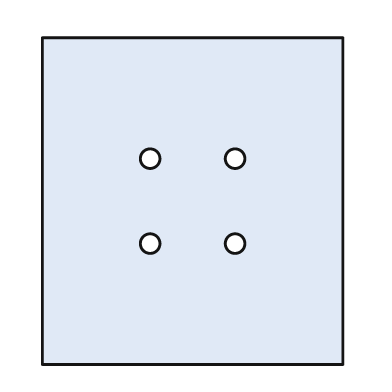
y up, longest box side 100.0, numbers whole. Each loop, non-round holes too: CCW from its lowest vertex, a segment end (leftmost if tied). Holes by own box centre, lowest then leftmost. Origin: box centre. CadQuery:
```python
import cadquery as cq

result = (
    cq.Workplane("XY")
    .moveTo(-46.0, -50.0)
    .lineTo(46.0, -50.0)
    .lineTo(46.0, 50.0)
    .lineTo(-46.0, 50.0)
    .close()
    .moveTo(-13.0, -13.0)
    .circle(3.0)
    .moveTo(13.0, -13.0)
    .circle(3.0)
    .moveTo(-13.0, 13.0)
    .circle(3.0)
    .moveTo(13.0, 13.0)
    .circle(3.0)
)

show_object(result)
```